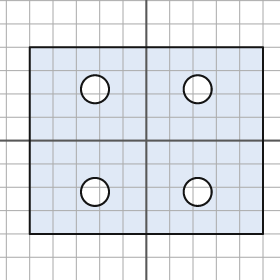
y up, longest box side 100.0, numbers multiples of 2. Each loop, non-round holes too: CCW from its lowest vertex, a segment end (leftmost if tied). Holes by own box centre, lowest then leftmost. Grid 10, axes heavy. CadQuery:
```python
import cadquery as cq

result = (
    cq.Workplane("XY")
    .moveTo(-50.0, -40.0)
    .lineTo(50.0, -40.0)
    .lineTo(50.0, 40.0)
    .lineTo(-50.0, 40.0)
    .close()
    .moveTo(-22.0, -22.0)
    .circle(6.0)
    .moveTo(22.0, -22.0)
    .circle(6.0)
    .moveTo(-22.0, 22.0)
    .circle(6.0)
    .moveTo(22.0, 22.0)
    .circle(6.0)
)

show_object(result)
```